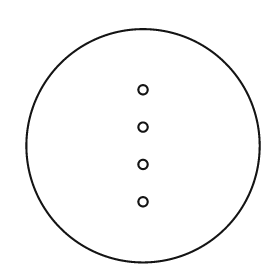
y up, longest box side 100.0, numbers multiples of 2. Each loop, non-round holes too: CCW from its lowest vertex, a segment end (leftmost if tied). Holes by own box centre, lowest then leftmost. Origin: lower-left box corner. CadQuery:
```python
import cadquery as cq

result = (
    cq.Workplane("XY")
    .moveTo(50.0, 50.0)
    .circle(50.0)
    .moveTo(50.0, 26.0)
    .circle(2.0)
    .moveTo(50.0, 42.0)
    .circle(2.0)
    .moveTo(50.0, 58.0)
    .circle(2.0)
    .moveTo(50.0, 74.0)
    .circle(2.0)
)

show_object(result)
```